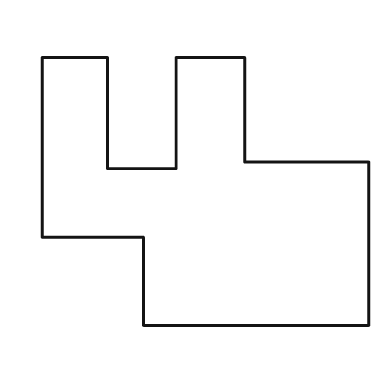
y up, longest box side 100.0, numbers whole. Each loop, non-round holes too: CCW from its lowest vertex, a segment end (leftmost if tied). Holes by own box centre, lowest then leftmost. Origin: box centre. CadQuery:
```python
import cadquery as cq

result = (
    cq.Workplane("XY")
    .moveTo(-19.0, -41.0)
    .lineTo(50.0, -41.0)
    .lineTo(50.0, 9.0)
    .lineTo(12.0, 9.0)
    .lineTo(12.0, 41.0)
    .lineTo(-9.0, 41.0)
    .lineTo(-9.0, 7.0)
    .lineTo(-30.0, 7.0)
    .lineTo(-30.0, 41.0)
    .lineTo(-50.0, 41.0)
    .lineTo(-50.0, -14.0)
    .lineTo(-19.0, -14.0)
    .close()
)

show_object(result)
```